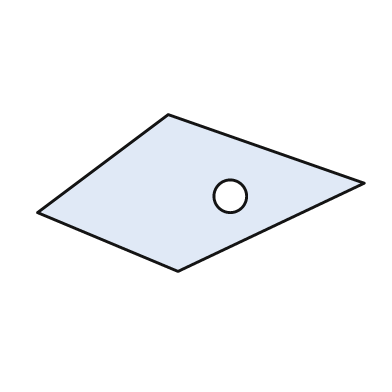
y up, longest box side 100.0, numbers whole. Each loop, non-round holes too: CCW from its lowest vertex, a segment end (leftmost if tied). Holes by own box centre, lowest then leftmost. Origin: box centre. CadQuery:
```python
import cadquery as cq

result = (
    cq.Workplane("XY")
    .moveTo(-7.0, -24.0)
    .lineTo(50.0, 3.0)
    .lineTo(-10.0, 24.0)
    .lineTo(-50.0, -6.0)
    .close()
    .moveTo(9.0, -1.0)
    .circle(5.0)
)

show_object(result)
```